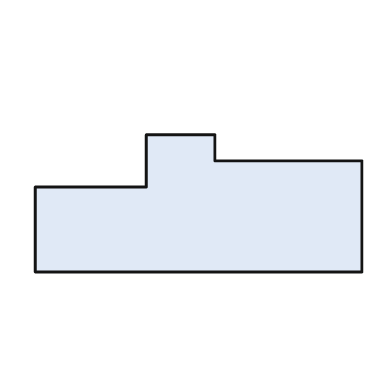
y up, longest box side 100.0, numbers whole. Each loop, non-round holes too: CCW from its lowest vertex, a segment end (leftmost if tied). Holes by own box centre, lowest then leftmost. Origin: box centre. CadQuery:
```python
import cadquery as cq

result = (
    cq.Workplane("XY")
    .moveTo(-50.0, -21.0)
    .lineTo(50.0, -21.0)
    .lineTo(50.0, 13.0)
    .lineTo(5.0, 13.0)
    .lineTo(5.0, 21.0)
    .lineTo(-16.0, 21.0)
    .lineTo(-16.0, 5.0)
    .lineTo(-50.0, 5.0)
    .close()
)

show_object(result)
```